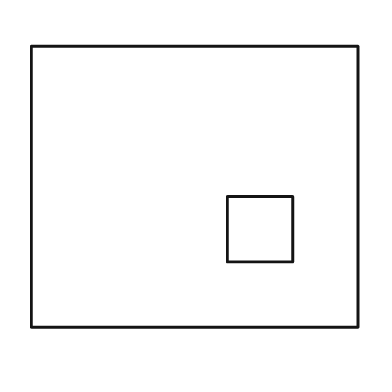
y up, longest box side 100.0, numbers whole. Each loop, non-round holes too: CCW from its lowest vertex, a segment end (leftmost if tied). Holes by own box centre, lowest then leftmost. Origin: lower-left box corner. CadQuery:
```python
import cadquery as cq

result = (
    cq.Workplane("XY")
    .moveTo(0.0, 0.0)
    .lineTo(100.0, 0.0)
    .lineTo(100.0, 86.0)
    .lineTo(0.0, 86.0)
    .close()
    .moveTo(60.0, 20.0)
    .lineTo(80.0, 20.0)
    .lineTo(80.0, 40.0)
    .lineTo(60.0, 40.0)
    .close()
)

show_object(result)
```